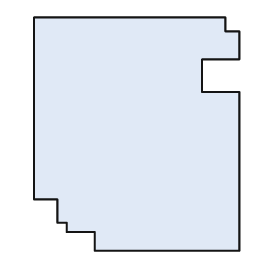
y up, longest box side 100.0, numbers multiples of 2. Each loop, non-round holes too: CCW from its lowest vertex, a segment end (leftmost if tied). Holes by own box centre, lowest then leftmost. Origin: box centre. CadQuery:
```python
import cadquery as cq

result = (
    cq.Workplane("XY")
    .moveTo(-18.0, -50.0)
    .lineTo(44.0, -50.0)
    .lineTo(44.0, 18.0)
    .lineTo(28.0, 18.0)
    .lineTo(28.0, 32.0)
    .lineTo(44.0, 32.0)
    .lineTo(44.0, 44.0)
    .lineTo(38.0, 44.0)
    .lineTo(38.0, 50.0)
    .lineTo(-44.0, 50.0)
    .lineTo(-44.0, -28.0)
    .lineTo(-34.0, -28.0)
    .lineTo(-34.0, -38.0)
    .lineTo(-30.0, -38.0)
    .lineTo(-30.0, -42.0)
    .lineTo(-18.0, -42.0)
    .close()
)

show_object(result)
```